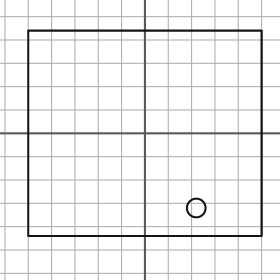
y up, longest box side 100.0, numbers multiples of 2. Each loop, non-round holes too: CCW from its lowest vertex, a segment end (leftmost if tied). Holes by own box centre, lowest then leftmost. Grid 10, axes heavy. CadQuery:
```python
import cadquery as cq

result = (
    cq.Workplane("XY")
    .moveTo(-50.0, -44.0)
    .lineTo(50.0, -44.0)
    .lineTo(50.0, 44.0)
    .lineTo(-50.0, 44.0)
    .close()
    .moveTo(22.0, -32.0)
    .circle(4.0)
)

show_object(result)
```